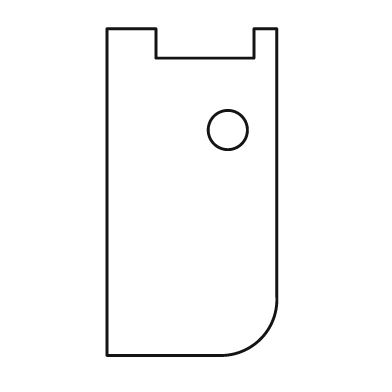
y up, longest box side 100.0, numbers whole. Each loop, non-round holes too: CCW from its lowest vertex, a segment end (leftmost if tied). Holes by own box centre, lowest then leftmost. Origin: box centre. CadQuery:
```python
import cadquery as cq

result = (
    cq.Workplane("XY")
    .moveTo(-26.0, -50.0)
    .lineTo(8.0, -50.0)
    .threePointArc((21.0, -45.0), (26.0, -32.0))
    .lineTo(26.0, 50.0)
    .lineTo(19.0, 50.0)
    .lineTo(19.0, 41.0)
    .lineTo(-11.0, 41.0)
    .lineTo(-11.0, 50.0)
    .lineTo(-26.0, 50.0)
    .close()
    .moveTo(11.0, 19.0)
    .circle(6.0)
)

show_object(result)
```